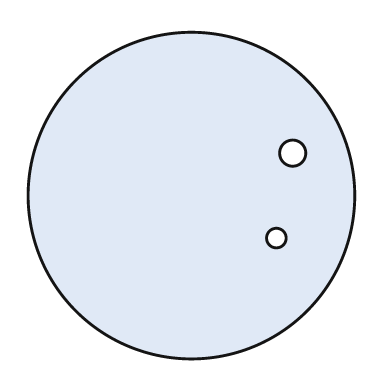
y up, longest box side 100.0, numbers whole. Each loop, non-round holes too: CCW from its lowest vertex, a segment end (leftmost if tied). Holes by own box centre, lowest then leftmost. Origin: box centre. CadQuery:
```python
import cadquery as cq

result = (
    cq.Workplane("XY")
    .moveTo(0.0, 0.0)
    .circle(50.0)
    .moveTo(26.0, -13.0)
    .circle(3.0)
    .moveTo(31.0, 13.0)
    .circle(4.0)
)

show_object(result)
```